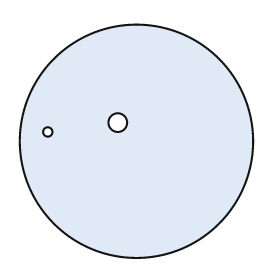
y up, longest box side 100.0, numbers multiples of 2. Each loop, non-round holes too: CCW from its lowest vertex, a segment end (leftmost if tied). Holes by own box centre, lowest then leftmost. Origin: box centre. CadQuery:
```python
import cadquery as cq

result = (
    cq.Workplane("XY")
    .moveTo(0.0, 0.0)
    .circle(50.0)
    .moveTo(-38.0, 4.0)
    .circle(2.0)
    .moveTo(-8.0, 8.0)
    .circle(4.0)
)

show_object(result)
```